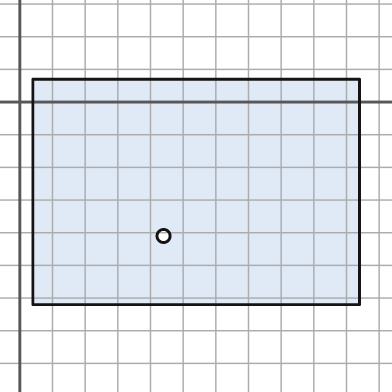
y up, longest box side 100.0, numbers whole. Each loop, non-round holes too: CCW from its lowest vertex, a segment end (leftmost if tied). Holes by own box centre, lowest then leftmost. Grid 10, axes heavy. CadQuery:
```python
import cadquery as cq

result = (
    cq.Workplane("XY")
    .moveTo(4.0, -62.0)
    .lineTo(104.0, -62.0)
    .lineTo(104.0, 7.0)
    .lineTo(4.0, 7.0)
    .close()
    .moveTo(44.0, -41.0)
    .circle(2.0)
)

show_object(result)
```